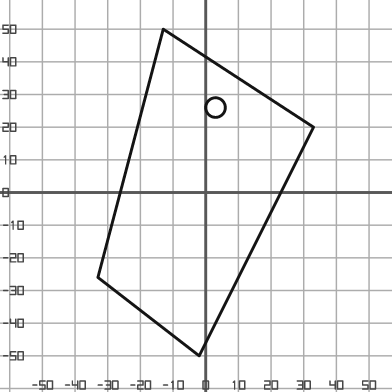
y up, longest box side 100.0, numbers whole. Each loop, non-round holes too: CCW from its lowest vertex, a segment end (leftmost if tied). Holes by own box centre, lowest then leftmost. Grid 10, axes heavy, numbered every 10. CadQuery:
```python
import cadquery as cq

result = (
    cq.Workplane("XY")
    .moveTo(-2.0, -50.0)
    .lineTo(33.0, 20.0)
    .lineTo(-13.0, 50.0)
    .lineTo(-33.0, -26.0)
    .close()
    .moveTo(3.0, 26.0)
    .circle(3.0)
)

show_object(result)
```